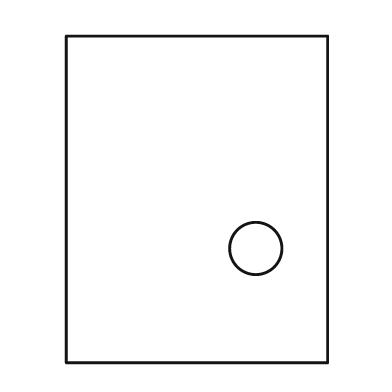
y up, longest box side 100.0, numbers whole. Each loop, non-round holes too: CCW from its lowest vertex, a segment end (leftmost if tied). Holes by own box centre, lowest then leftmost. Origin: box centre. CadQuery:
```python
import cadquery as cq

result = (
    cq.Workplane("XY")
    .moveTo(-40.0, -50.0)
    .lineTo(40.0, -50.0)
    .lineTo(40.0, 50.0)
    .lineTo(-40.0, 50.0)
    .close()
    .moveTo(18.0, -15.0)
    .circle(8.0)
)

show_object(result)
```